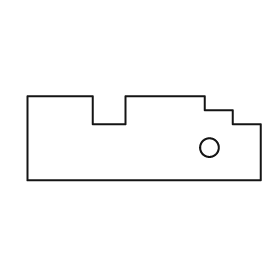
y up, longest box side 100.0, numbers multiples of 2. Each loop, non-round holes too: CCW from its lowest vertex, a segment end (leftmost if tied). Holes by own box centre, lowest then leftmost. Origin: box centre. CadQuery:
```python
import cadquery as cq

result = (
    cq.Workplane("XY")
    .moveTo(-50.0, -18.0)
    .lineTo(50.0, -18.0)
    .lineTo(50.0, 6.0)
    .lineTo(38.0, 6.0)
    .lineTo(38.0, 12.0)
    .lineTo(26.0, 12.0)
    .lineTo(26.0, 18.0)
    .lineTo(-8.0, 18.0)
    .lineTo(-8.0, 6.0)
    .lineTo(-22.0, 6.0)
    .lineTo(-22.0, 18.0)
    .lineTo(-50.0, 18.0)
    .close()
    .moveTo(28.0, -4.0)
    .circle(4.0)
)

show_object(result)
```